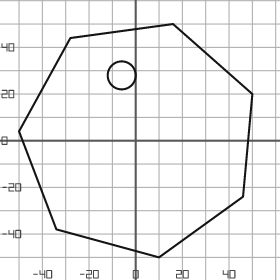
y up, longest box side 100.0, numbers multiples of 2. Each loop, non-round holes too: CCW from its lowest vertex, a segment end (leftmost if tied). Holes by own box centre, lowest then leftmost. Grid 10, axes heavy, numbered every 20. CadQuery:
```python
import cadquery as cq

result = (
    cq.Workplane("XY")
    .moveTo(10.0, -50.0)
    .lineTo(46.0, -24.0)
    .lineTo(50.0, 20.0)
    .lineTo(16.0, 50.0)
    .lineTo(-28.0, 44.0)
    .lineTo(-50.0, 4.0)
    .lineTo(-34.0, -38.0)
    .close()
    .moveTo(-6.0, 28.0)
    .circle(6.0)
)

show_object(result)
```